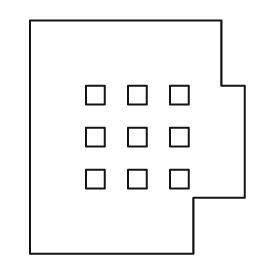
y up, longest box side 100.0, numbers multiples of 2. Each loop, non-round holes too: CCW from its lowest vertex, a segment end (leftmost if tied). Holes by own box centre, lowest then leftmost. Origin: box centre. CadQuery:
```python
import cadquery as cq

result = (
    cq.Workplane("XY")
    .moveTo(-46.0, -50.0)
    .lineTo(24.0, -50.0)
    .lineTo(24.0, -26.0)
    .lineTo(46.0, -26.0)
    .lineTo(46.0, 22.0)
    .lineTo(36.0, 22.0)
    .lineTo(36.0, 50.0)
    .lineTo(-46.0, 50.0)
    .close()
    .moveTo(-22.0, -22.0)
    .lineTo(-14.0, -22.0)
    .lineTo(-14.0, -14.0)
    .lineTo(-22.0, -14.0)
    .close()
    .moveTo(-4.0, -22.0)
    .lineTo(4.0, -22.0)
    .lineTo(4.0, -14.0)
    .lineTo(-4.0, -14.0)
    .close()
    .moveTo(14.0, -22.0)
    .lineTo(22.0, -22.0)
    .lineTo(22.0, -14.0)
    .lineTo(14.0, -14.0)
    .close()
    .moveTo(-22.0, -4.0)
    .lineTo(-14.0, -4.0)
    .lineTo(-14.0, 4.0)
    .lineTo(-22.0, 4.0)
    .close()
    .moveTo(-4.0, -4.0)
    .lineTo(4.0, -4.0)
    .lineTo(4.0, 4.0)
    .lineTo(-4.0, 4.0)
    .close()
    .moveTo(14.0, -4.0)
    .lineTo(22.0, -4.0)
    .lineTo(22.0, 4.0)
    .lineTo(14.0, 4.0)
    .close()
    .moveTo(-22.0, 14.0)
    .lineTo(-14.0, 14.0)
    .lineTo(-14.0, 22.0)
    .lineTo(-22.0, 22.0)
    .close()
    .moveTo(-4.0, 14.0)
    .lineTo(4.0, 14.0)
    .lineTo(4.0, 22.0)
    .lineTo(-4.0, 22.0)
    .close()
    .moveTo(14.0, 14.0)
    .lineTo(22.0, 14.0)
    .lineTo(22.0, 22.0)
    .lineTo(14.0, 22.0)
    .close()
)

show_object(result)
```